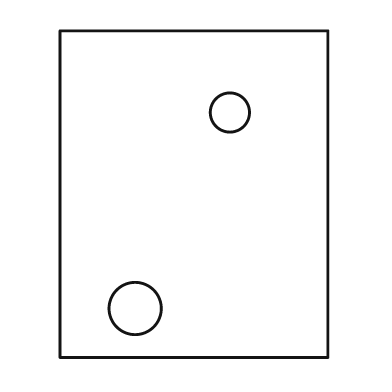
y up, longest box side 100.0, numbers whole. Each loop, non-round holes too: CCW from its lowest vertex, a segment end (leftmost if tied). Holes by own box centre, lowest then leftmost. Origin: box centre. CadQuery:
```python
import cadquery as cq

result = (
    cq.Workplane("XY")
    .moveTo(-41.0, -50.0)
    .lineTo(41.0, -50.0)
    .lineTo(41.0, 50.0)
    .lineTo(-41.0, 50.0)
    .close()
    .moveTo(-18.0, -35.0)
    .circle(8.0)
    .moveTo(11.0, 25.0)
    .circle(6.0)
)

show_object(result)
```